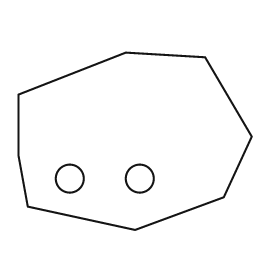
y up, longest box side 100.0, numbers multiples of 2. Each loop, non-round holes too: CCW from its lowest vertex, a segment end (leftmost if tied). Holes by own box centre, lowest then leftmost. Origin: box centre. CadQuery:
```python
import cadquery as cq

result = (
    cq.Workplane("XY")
    .moveTo(0.0, -38.0)
    .lineTo(38.0, -24.0)
    .lineTo(50.0, 2.0)
    .lineTo(30.0, 36.0)
    .lineTo(-4.0, 38.0)
    .lineTo(-50.0, 20.0)
    .lineTo(-50.0, -6.0)
    .lineTo(-46.0, -28.0)
    .close()
    .moveTo(-28.0, -16.0)
    .circle(6.0)
    .moveTo(2.0, -16.0)
    .circle(6.0)
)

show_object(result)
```